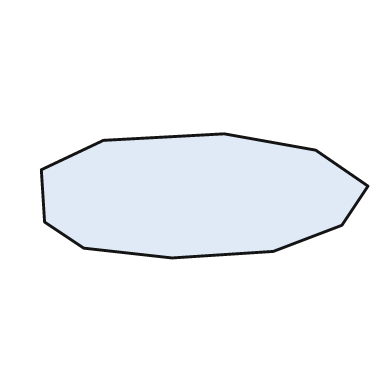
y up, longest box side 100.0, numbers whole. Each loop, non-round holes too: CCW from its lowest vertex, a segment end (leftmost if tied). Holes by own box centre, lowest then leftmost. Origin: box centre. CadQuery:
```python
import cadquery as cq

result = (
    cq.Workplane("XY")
    .moveTo(-10.0, -19.0)
    .lineTo(21.0, -17.0)
    .lineTo(42.0, -9.0)
    .lineTo(50.0, 3.0)
    .lineTo(34.0, 14.0)
    .lineTo(6.0, 19.0)
    .lineTo(-31.0, 17.0)
    .lineTo(-50.0, 8.0)
    .lineTo(-49.0, -8.0)
    .lineTo(-37.0, -16.0)
    .close()
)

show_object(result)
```